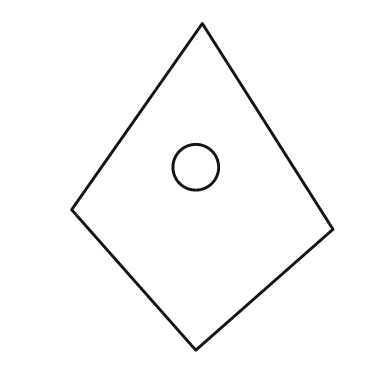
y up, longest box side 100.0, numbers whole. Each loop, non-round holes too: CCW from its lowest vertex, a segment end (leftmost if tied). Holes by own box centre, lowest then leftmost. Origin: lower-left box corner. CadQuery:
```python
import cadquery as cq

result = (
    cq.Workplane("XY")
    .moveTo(38.0, 0.0)
    .lineTo(80.0, 37.0)
    .lineTo(40.0, 100.0)
    .lineTo(0.0, 43.0)
    .close()
    .moveTo(38.0, 56.0)
    .circle(7.0)
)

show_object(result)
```